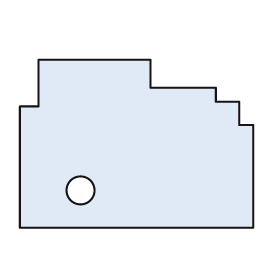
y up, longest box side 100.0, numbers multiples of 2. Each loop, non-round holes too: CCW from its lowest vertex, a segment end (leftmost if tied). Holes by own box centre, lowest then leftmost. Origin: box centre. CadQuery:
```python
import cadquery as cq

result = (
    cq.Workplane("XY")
    .moveTo(-50.0, -36.0)
    .lineTo(50.0, -36.0)
    .lineTo(50.0, 8.0)
    .lineTo(44.0, 8.0)
    .lineTo(44.0, 18.0)
    .lineTo(34.0, 18.0)
    .lineTo(34.0, 24.0)
    .lineTo(6.0, 24.0)
    .lineTo(6.0, 36.0)
    .lineTo(-42.0, 36.0)
    .lineTo(-42.0, 16.0)
    .lineTo(-50.0, 16.0)
    .close()
    .moveTo(-24.0, -20.0)
    .circle(6.0)
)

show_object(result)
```